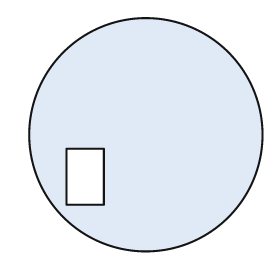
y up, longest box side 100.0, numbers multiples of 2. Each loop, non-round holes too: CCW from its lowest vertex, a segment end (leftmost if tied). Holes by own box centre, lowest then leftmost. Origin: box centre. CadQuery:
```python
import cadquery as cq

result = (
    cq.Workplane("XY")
    .moveTo(0.0, 0.0)
    .circle(50.0)
    .moveTo(-34.0, -30.0)
    .lineTo(-18.0, -30.0)
    .lineTo(-18.0, -6.0)
    .lineTo(-34.0, -6.0)
    .close()
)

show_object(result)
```